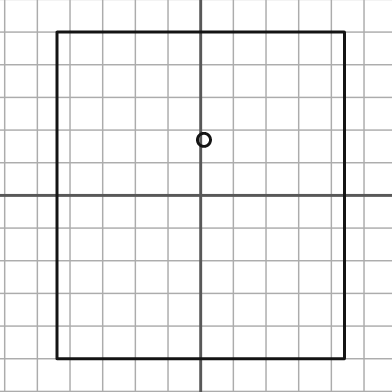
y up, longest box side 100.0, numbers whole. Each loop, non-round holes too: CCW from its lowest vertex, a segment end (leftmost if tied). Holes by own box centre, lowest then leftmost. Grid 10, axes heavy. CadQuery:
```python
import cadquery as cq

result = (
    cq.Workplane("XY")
    .moveTo(-44.0, -50.0)
    .lineTo(44.0, -50.0)
    .lineTo(44.0, 50.0)
    .lineTo(-44.0, 50.0)
    .close()
    .moveTo(1.0, 17.0)
    .circle(2.0)
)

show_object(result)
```